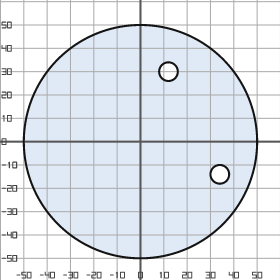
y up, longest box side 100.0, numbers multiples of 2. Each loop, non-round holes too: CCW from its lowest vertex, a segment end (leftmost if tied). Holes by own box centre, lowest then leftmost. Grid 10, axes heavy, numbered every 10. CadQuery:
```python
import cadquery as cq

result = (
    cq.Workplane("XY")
    .moveTo(0.0, 0.0)
    .circle(50.0)
    .moveTo(34.0, -14.0)
    .circle(4.0)
    .moveTo(12.0, 30.0)
    .circle(4.0)
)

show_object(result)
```